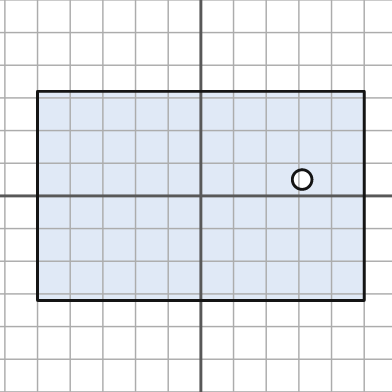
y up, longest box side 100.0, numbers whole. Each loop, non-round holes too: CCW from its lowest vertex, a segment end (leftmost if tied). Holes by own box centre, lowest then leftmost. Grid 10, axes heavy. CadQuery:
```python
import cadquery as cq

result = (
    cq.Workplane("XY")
    .moveTo(-50.0, -32.0)
    .lineTo(50.0, -32.0)
    .lineTo(50.0, 32.0)
    .lineTo(-50.0, 32.0)
    .close()
    .moveTo(31.0, 5.0)
    .circle(3.0)
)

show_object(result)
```